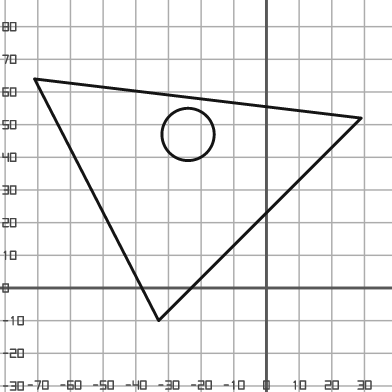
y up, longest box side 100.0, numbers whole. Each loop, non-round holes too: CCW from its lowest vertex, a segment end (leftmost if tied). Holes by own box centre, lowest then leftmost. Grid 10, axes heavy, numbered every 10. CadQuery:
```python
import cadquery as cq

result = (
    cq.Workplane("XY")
    .moveTo(-33.0, -10.0)
    .lineTo(29.0, 52.0)
    .lineTo(-71.0, 64.0)
    .close()
    .moveTo(-24.0, 47.0)
    .circle(8.0)
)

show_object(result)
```